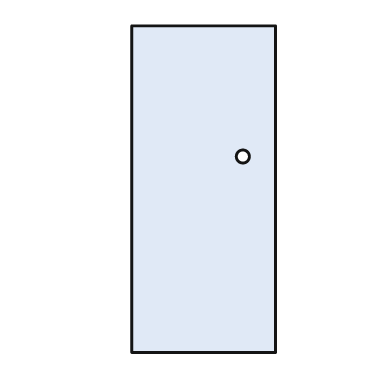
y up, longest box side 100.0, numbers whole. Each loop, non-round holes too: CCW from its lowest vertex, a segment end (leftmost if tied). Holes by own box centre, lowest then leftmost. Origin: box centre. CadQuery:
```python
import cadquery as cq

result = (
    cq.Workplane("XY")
    .moveTo(-22.0, -50.0)
    .lineTo(22.0, -50.0)
    .lineTo(22.0, 50.0)
    .lineTo(-22.0, 50.0)
    .close()
    .moveTo(12.0, 10.0)
    .circle(2.0)
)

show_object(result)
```